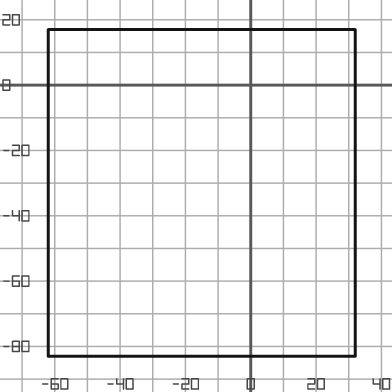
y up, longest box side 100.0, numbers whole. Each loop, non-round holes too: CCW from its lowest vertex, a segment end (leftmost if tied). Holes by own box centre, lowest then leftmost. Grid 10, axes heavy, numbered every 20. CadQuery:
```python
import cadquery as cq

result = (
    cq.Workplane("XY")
    .moveTo(-62.0, -83.0)
    .lineTo(32.0, -83.0)
    .lineTo(32.0, 17.0)
    .lineTo(-62.0, 17.0)
    .close()
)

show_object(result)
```